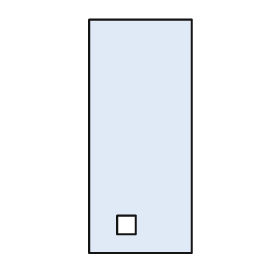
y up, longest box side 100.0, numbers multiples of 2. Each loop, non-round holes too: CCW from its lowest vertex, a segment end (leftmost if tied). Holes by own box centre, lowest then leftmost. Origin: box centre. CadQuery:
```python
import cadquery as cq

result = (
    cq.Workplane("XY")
    .moveTo(-22.0, -50.0)
    .lineTo(22.0, -50.0)
    .lineTo(22.0, 50.0)
    .lineTo(-22.0, 50.0)
    .close()
    .moveTo(-10.0, -42.0)
    .lineTo(-2.0, -42.0)
    .lineTo(-2.0, -34.0)
    .lineTo(-10.0, -34.0)
    .close()
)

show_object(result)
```